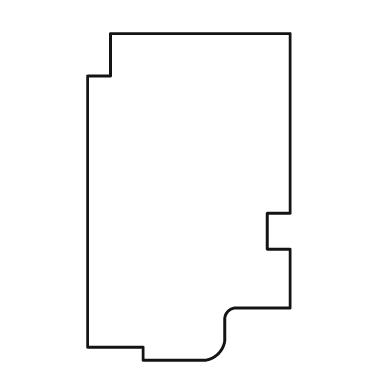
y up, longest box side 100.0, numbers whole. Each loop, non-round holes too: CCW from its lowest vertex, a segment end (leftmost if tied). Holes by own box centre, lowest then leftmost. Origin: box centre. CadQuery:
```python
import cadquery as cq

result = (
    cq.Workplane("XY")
    .moveTo(-14.0, -50.0)
    .lineTo(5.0, -50.0)
    .threePointArc((9.0, -48.0), (11.0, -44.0))
    .lineTo(11.0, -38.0)
    .threePointArc((12.0, -35.0), (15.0, -34.0))
    .lineTo(31.0, -34.0)
    .lineTo(31.0, -16.0)
    .lineTo(24.0, -16.0)
    .lineTo(24.0, -5.0)
    .lineTo(31.0, -5.0)
    .lineTo(31.0, 50.0)
    .lineTo(-24.0, 50.0)
    .lineTo(-24.0, 37.0)
    .lineTo(-31.0, 37.0)
    .lineTo(-31.0, -46.0)
    .lineTo(-14.0, -46.0)
    .close()
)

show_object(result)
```